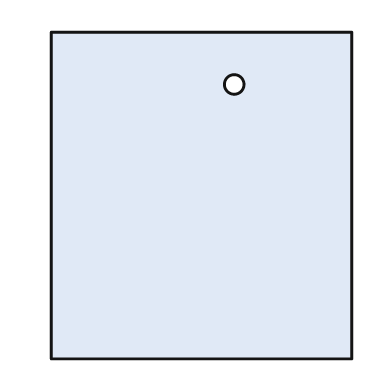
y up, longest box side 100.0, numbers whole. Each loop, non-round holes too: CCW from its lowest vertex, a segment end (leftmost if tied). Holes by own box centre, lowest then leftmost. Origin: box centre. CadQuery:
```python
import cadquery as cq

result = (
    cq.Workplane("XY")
    .moveTo(-46.0, -50.0)
    .lineTo(46.0, -50.0)
    .lineTo(46.0, 50.0)
    .lineTo(-46.0, 50.0)
    .close()
    .moveTo(10.0, 34.0)
    .circle(3.0)
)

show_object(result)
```